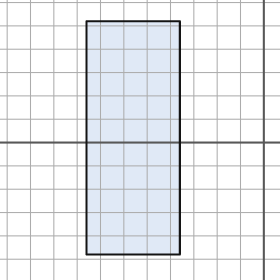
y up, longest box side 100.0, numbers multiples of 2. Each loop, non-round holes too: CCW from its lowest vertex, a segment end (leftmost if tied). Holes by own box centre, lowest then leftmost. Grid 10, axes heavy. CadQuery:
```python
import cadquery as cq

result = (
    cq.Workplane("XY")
    .moveTo(-76.0, -48.0)
    .lineTo(-36.0, -48.0)
    .lineTo(-36.0, 52.0)
    .lineTo(-76.0, 52.0)
    .close()
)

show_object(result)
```